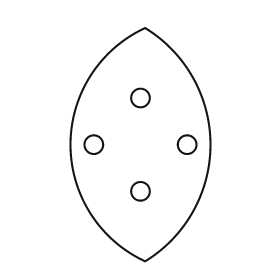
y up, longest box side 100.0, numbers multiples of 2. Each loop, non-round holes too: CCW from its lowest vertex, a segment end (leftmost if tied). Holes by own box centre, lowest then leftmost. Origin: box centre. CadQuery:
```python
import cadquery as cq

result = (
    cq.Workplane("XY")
    .moveTo(2.0, -50.0)
    .threePointArc((30.0, 0.0), (2.0, 50.0))
    .threePointArc((-30.0, 0.0), (2.0, -50.0))
    .close()
    .moveTo(0.0, -20.0)
    .circle(4.0)
    .moveTo(-20.0, 0.0)
    .circle(4.0)
    .moveTo(20.0, 0.0)
    .circle(4.0)
    .moveTo(0.0, 20.0)
    .circle(4.0)
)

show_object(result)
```